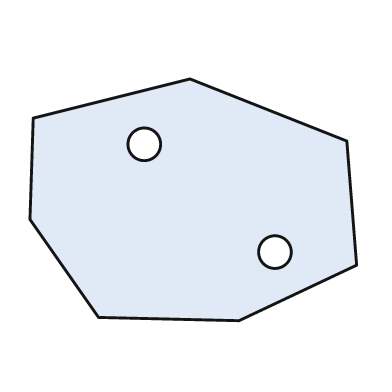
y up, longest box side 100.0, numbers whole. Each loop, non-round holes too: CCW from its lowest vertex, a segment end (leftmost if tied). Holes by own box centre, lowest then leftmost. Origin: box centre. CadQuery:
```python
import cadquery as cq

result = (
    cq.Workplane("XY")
    .moveTo(14.0, -37.0)
    .lineTo(50.0, -20.0)
    .lineTo(47.0, 18.0)
    .lineTo(-1.0, 37.0)
    .lineTo(-49.0, 25.0)
    .lineTo(-50.0, -6.0)
    .lineTo(-29.0, -36.0)
    .close()
    .moveTo(25.0, -16.0)
    .circle(5.0)
    .moveTo(-15.0, 17.0)
    .circle(5.0)
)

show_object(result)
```